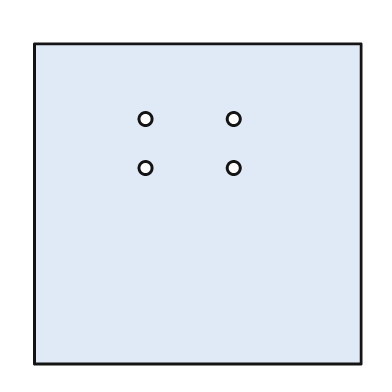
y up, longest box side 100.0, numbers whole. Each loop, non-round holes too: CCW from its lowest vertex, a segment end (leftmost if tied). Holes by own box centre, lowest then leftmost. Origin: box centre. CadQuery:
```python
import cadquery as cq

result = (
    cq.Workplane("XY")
    .moveTo(-50.0, -49.0)
    .lineTo(50.0, -49.0)
    .lineTo(50.0, 49.0)
    .lineTo(-50.0, 49.0)
    .close()
    .moveTo(-16.0, 11.0)
    .circle(2.0)
    .moveTo(11.0, 11.0)
    .circle(2.0)
    .moveTo(-16.0, 26.0)
    .circle(2.0)
    .moveTo(11.0, 26.0)
    .circle(2.0)
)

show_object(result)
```